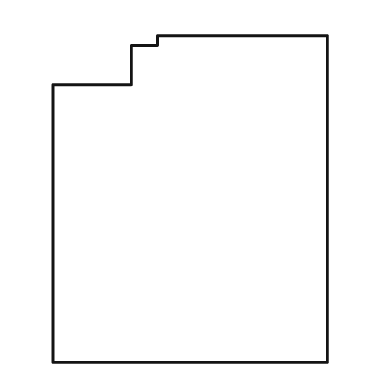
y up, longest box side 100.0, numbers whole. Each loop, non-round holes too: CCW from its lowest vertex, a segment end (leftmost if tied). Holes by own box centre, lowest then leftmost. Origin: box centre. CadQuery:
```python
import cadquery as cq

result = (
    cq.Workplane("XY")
    .moveTo(-42.0, -50.0)
    .lineTo(42.0, -50.0)
    .lineTo(42.0, 50.0)
    .lineTo(-10.0, 50.0)
    .lineTo(-10.0, 47.0)
    .lineTo(-18.0, 47.0)
    .lineTo(-18.0, 35.0)
    .lineTo(-42.0, 35.0)
    .close()
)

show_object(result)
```